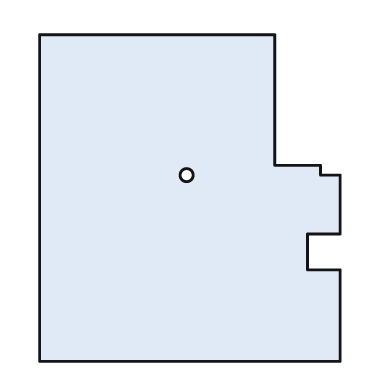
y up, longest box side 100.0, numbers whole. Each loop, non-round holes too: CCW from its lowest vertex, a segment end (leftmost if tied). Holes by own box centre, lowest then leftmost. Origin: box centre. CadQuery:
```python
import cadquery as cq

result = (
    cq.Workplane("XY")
    .moveTo(-46.0, -50.0)
    .lineTo(46.0, -50.0)
    .lineTo(46.0, -22.0)
    .lineTo(36.0, -22.0)
    .lineTo(36.0, -11.0)
    .lineTo(46.0, -11.0)
    .lineTo(46.0, 7.0)
    .lineTo(40.0, 7.0)
    .lineTo(40.0, 10.0)
    .lineTo(26.0, 10.0)
    .lineTo(26.0, 50.0)
    .lineTo(-46.0, 50.0)
    .close()
    .moveTo(-1.0, 7.0)
    .circle(2.0)
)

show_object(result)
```